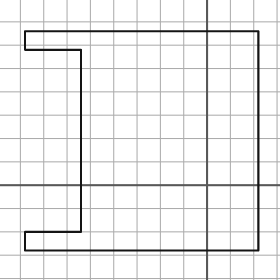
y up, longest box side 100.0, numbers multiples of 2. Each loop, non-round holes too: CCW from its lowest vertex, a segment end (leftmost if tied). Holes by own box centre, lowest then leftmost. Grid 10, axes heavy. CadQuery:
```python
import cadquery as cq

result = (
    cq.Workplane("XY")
    .moveTo(-78.0, -28.0)
    .lineTo(22.0, -28.0)
    .lineTo(22.0, 66.0)
    .lineTo(-78.0, 66.0)
    .lineTo(-78.0, 58.0)
    .lineTo(-54.0, 58.0)
    .lineTo(-54.0, -20.0)
    .lineTo(-78.0, -20.0)
    .close()
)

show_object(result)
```